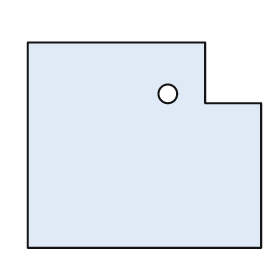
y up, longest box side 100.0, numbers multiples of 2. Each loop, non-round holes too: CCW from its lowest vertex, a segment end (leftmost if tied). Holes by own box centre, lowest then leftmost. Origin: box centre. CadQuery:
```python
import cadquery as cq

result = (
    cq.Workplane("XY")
    .moveTo(-50.0, -44.0)
    .lineTo(50.0, -44.0)
    .lineTo(50.0, 18.0)
    .lineTo(26.0, 18.0)
    .lineTo(26.0, 44.0)
    .lineTo(-50.0, 44.0)
    .close()
    .moveTo(10.0, 22.0)
    .circle(4.0)
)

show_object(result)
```